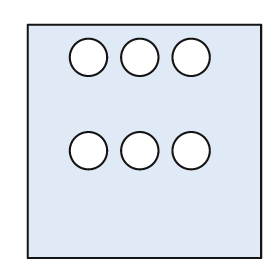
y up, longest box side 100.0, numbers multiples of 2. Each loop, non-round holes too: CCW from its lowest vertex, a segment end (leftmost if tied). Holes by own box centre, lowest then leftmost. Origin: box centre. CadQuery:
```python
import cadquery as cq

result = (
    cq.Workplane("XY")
    .moveTo(-50.0, -50.0)
    .lineTo(50.0, -50.0)
    .lineTo(50.0, 50.0)
    .lineTo(-50.0, 50.0)
    .close()
    .moveTo(-24.0, -4.0)
    .circle(8.0)
    .moveTo(-2.0, -4.0)
    .circle(8.0)
    .moveTo(20.0, -4.0)
    .circle(8.0)
    .moveTo(-24.0, 36.0)
    .circle(8.0)
    .moveTo(-2.0, 36.0)
    .circle(8.0)
    .moveTo(20.0, 36.0)
    .circle(8.0)
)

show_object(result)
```